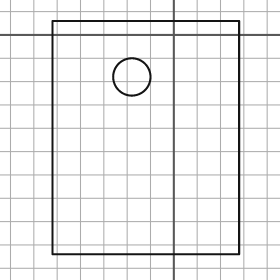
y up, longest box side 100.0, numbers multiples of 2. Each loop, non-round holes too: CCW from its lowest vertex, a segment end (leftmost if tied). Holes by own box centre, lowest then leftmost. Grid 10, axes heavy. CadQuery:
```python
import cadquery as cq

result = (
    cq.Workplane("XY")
    .moveTo(-52.0, -94.0)
    .lineTo(28.0, -94.0)
    .lineTo(28.0, 6.0)
    .lineTo(-52.0, 6.0)
    .close()
    .moveTo(-18.0, -18.0)
    .circle(8.0)
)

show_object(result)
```